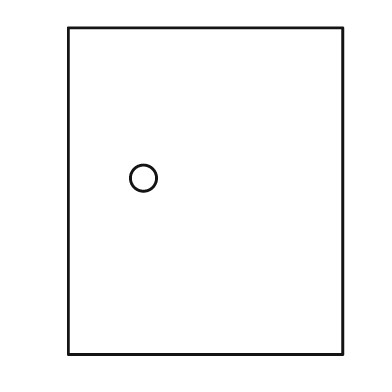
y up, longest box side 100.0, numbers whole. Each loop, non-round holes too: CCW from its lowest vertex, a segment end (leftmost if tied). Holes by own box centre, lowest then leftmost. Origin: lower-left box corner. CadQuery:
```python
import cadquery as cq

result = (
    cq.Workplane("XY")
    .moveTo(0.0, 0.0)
    .lineTo(84.0, 0.0)
    .lineTo(84.0, 100.0)
    .lineTo(0.0, 100.0)
    .close()
    .moveTo(23.0, 54.0)
    .circle(4.0)
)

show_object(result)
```